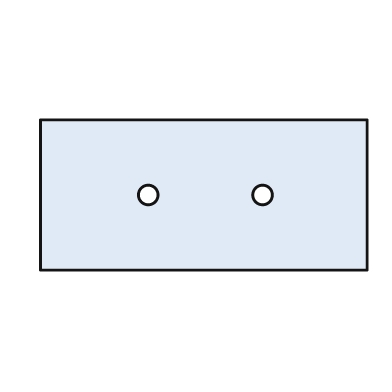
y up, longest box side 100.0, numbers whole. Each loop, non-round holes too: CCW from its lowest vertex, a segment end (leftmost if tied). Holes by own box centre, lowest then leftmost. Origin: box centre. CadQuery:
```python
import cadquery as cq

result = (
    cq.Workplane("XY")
    .moveTo(-50.0, -23.0)
    .lineTo(50.0, -23.0)
    .lineTo(50.0, 23.0)
    .lineTo(-50.0, 23.0)
    .close()
    .moveTo(-17.0, 0.0)
    .circle(3.0)
    .moveTo(18.0, 0.0)
    .circle(3.0)
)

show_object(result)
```